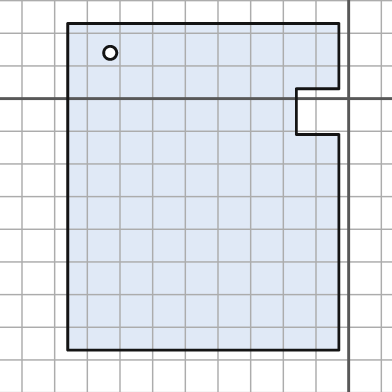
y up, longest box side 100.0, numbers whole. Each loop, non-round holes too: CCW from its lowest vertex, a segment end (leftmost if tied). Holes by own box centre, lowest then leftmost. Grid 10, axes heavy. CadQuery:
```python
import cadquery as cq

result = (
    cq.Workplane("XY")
    .moveTo(-86.0, -77.0)
    .lineTo(-3.0, -77.0)
    .lineTo(-3.0, -11.0)
    .lineTo(-16.0, -11.0)
    .lineTo(-16.0, 3.0)
    .lineTo(-3.0, 3.0)
    .lineTo(-3.0, 23.0)
    .lineTo(-86.0, 23.0)
    .close()
    .moveTo(-73.0, 14.0)
    .circle(2.0)
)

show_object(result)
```